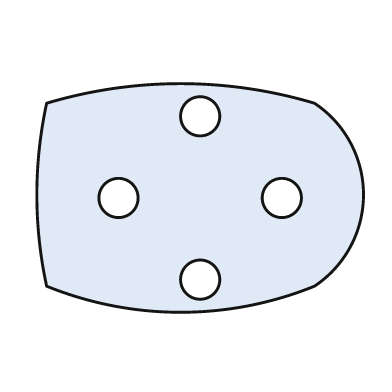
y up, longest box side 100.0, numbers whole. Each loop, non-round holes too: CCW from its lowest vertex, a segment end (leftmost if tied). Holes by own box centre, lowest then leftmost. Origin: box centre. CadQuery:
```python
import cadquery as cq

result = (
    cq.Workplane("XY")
    .moveTo(-47.0, -27.0)
    .threePointArc((-6.0, -35.0), (35.0, -27.0))
    .threePointArc((50.0, 1.0), (35.0, 29.0))
    .threePointArc((-6.0, 35.0), (-47.0, 29.0))
    .threePointArc((-50.0, 1.0), (-47.0, -27.0))
    .close()
    .moveTo(0.0, -25.0)
    .circle(6.0)
    .moveTo(-25.0, 0.0)
    .circle(6.0)
    .moveTo(25.0, 0.0)
    .circle(6.0)
    .moveTo(0.0, 25.0)
    .circle(6.0)
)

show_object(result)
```